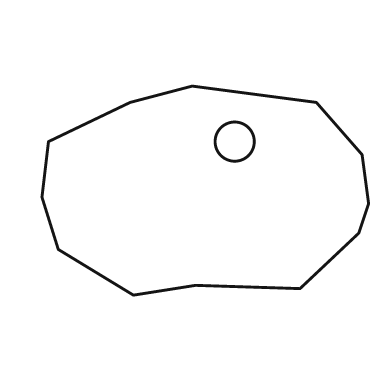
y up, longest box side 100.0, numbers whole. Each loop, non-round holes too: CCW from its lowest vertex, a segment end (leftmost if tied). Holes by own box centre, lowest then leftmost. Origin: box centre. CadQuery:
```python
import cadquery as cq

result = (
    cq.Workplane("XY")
    .moveTo(-22.0, -32.0)
    .lineTo(-3.0, -29.0)
    .lineTo(29.0, -30.0)
    .lineTo(47.0, -13.0)
    .lineTo(50.0, -4.0)
    .lineTo(48.0, 11.0)
    .lineTo(34.0, 27.0)
    .lineTo(-4.0, 32.0)
    .lineTo(-23.0, 27.0)
    .lineTo(-48.0, 15.0)
    .lineTo(-50.0, -2.0)
    .lineTo(-45.0, -18.0)
    .close()
    .moveTo(9.0, 15.0)
    .circle(6.0)
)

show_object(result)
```